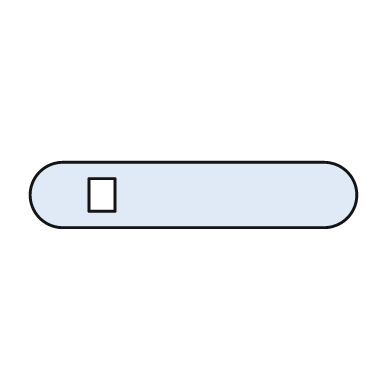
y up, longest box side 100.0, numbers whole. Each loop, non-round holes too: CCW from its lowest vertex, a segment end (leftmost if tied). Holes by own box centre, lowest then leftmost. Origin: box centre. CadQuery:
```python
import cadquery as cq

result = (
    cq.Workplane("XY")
    .moveTo(-40.0, -10.0)
    .lineTo(40.0, -10.0)
    .threePointArc((50.0, 0.0), (40.0, 10.0))
    .lineTo(-40.0, 10.0)
    .threePointArc((-50.0, 0.0), (-40.0, -10.0))
    .close()
    .moveTo(-32.0, -5.0)
    .lineTo(-24.0, -5.0)
    .lineTo(-24.0, 5.0)
    .lineTo(-32.0, 5.0)
    .close()
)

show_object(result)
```